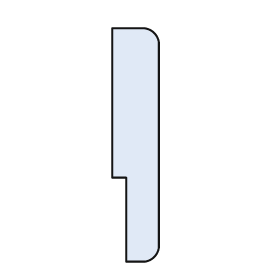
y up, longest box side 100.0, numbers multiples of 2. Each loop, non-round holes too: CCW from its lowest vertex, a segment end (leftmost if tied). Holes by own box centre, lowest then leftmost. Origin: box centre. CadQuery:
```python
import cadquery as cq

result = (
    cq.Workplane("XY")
    .moveTo(-4.0, -50.0)
    .lineTo(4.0, -50.0)
    .threePointArc((8.0, -48.0), (10.0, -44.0))
    .lineTo(10.0, 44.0)
    .threePointArc((8.0, 48.0), (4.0, 50.0))
    .lineTo(-10.0, 50.0)
    .lineTo(-10.0, -14.0)
    .lineTo(-4.0, -14.0)
    .close()
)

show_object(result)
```